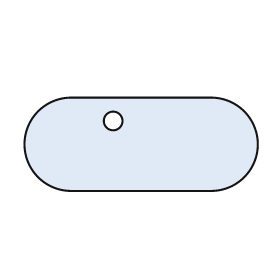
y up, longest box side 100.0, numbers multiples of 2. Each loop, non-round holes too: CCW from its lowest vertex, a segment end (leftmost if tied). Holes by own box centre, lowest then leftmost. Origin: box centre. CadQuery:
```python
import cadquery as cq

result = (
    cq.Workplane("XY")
    .moveTo(-30.0, -20.0)
    .lineTo(30.0, -20.0)
    .threePointArc((50.0, 0.0), (30.0, 20.0))
    .lineTo(-30.0, 20.0)
    .threePointArc((-50.0, 0.0), (-30.0, -20.0))
    .close()
    .moveTo(-12.0, 10.0)
    .circle(4.0)
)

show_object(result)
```